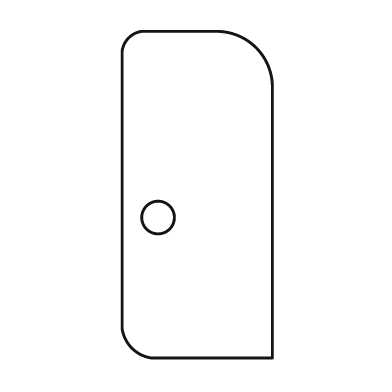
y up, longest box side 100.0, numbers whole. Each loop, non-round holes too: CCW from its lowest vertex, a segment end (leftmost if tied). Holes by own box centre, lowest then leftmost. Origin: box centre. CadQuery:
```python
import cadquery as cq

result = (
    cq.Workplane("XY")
    .moveTo(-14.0, -50.0)
    .lineTo(23.0, -50.0)
    .lineTo(23.0, 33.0)
    .threePointArc((18.0, 45.0), (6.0, 50.0))
    .lineTo(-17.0, 50.0)
    .threePointArc((-21.0, 48.0), (-23.0, 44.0))
    .lineTo(-23.0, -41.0)
    .threePointArc((-20.0, -47.0), (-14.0, -50.0))
    .close()
    .moveTo(-12.0, -7.0)
    .circle(5.0)
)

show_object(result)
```